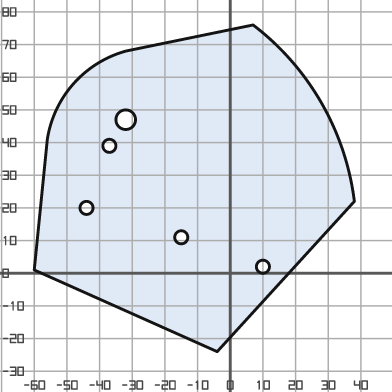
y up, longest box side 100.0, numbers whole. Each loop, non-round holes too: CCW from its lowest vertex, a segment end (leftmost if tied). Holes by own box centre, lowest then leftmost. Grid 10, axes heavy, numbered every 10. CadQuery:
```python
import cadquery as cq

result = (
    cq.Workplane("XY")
    .moveTo(-4.0, -24.0)
    .lineTo(38.0, 22.0)
    .threePointArc((28.0, 52.0), (7.0, 76.0))
    .lineTo(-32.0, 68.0)
    .threePointArc((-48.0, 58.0), (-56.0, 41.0))
    .lineTo(-60.0, 1.0)
    .close()
    .moveTo(10.0, 2.0)
    .circle(2.0)
    .moveTo(-15.0, 11.0)
    .circle(2.0)
    .moveTo(-44.0, 20.0)
    .circle(2.0)
    .moveTo(-37.0, 39.0)
    .circle(2.0)
    .moveTo(-32.0, 47.0)
    .circle(3.0)
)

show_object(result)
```